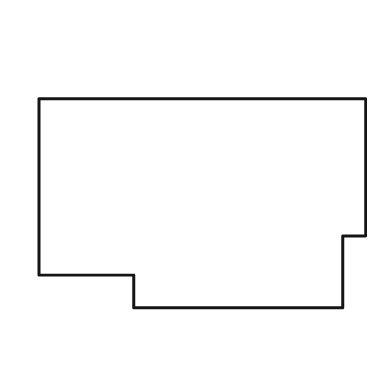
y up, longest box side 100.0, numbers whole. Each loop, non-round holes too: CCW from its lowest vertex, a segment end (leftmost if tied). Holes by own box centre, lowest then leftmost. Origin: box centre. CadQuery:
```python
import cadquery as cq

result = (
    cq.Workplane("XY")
    .moveTo(-21.0, -32.0)
    .lineTo(43.0, -32.0)
    .lineTo(43.0, -10.0)
    .lineTo(50.0, -10.0)
    .lineTo(50.0, 32.0)
    .lineTo(-50.0, 32.0)
    .lineTo(-50.0, -22.0)
    .lineTo(-21.0, -22.0)
    .close()
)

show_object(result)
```